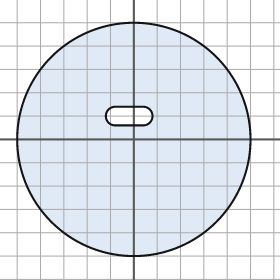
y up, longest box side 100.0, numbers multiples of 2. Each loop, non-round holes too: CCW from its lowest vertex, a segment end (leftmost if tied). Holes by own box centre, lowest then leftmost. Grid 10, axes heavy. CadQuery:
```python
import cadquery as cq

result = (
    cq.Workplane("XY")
    .moveTo(0.0, 0.0)
    .circle(50.0)
    .moveTo(-8.0, 6.0)
    .lineTo(4.0, 6.0)
    .threePointArc((8.0, 10.0), (4.0, 14.0))
    .lineTo(-8.0, 14.0)
    .threePointArc((-12.0, 10.0), (-8.0, 6.0))
    .close()
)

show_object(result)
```